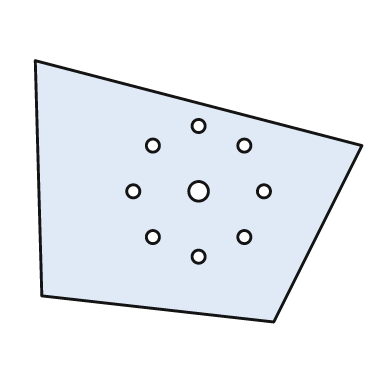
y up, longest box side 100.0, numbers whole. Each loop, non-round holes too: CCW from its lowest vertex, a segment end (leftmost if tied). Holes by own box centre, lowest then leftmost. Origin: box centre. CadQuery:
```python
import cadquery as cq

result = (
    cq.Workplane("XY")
    .moveTo(23.0, -40.0)
    .lineTo(50.0, 14.0)
    .lineTo(-50.0, 40.0)
    .lineTo(-48.0, -32.0)
    .close()
    .moveTo(0.0, -20.0)
    .circle(2.0)
    .moveTo(-14.0, -14.0)
    .circle(2.0)
    .moveTo(14.0, -14.0)
    .circle(2.0)
    .moveTo(-20.0, 0.0)
    .circle(2.0)
    .moveTo(0.0, 0.0)
    .circle(3.0)
    .moveTo(20.0, 0.0)
    .circle(2.0)
    .moveTo(-14.0, 14.0)
    .circle(2.0)
    .moveTo(14.0, 14.0)
    .circle(2.0)
    .moveTo(0.0, 20.0)
    .circle(2.0)
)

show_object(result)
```